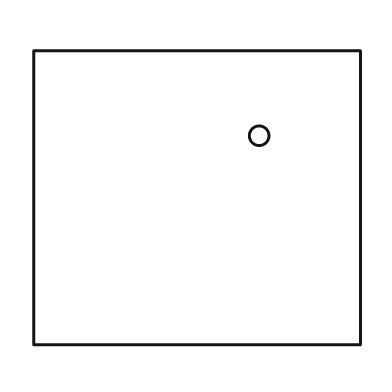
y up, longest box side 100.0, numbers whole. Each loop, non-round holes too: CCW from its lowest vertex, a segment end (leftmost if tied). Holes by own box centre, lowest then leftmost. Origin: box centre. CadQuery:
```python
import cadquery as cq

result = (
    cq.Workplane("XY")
    .moveTo(-50.0, -45.0)
    .lineTo(50.0, -45.0)
    .lineTo(50.0, 45.0)
    .lineTo(-50.0, 45.0)
    .close()
    .moveTo(19.0, 19.0)
    .circle(3.0)
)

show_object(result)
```